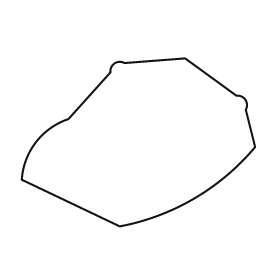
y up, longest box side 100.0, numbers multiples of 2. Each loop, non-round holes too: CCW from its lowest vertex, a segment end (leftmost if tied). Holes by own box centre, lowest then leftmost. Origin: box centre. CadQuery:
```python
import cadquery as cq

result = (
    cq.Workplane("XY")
    .moveTo(-8.0, -36.0)
    .threePointArc((24.0, -24.0), (50.0, -2.0))
    .lineTo(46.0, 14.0)
    .threePointArc((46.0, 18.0), (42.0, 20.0))
    .lineTo(20.0, 36.0)
    .lineTo(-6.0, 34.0)
    .threePointArc((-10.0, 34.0), (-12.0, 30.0))
    .lineTo(-30.0, 10.0)
    .threePointArc((-44.0, 0.0), (-50.0, -16.0))
    .close()
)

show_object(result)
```